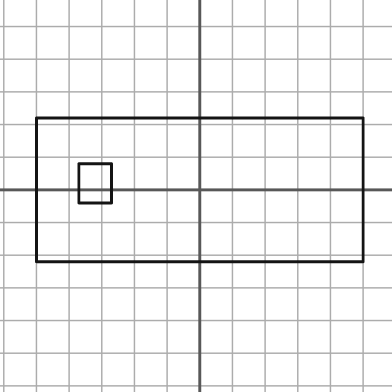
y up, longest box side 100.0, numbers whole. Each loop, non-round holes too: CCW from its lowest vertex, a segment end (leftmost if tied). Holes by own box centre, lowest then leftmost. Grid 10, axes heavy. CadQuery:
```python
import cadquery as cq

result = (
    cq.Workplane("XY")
    .moveTo(-50.0, -22.0)
    .lineTo(50.0, -22.0)
    .lineTo(50.0, 22.0)
    .lineTo(-50.0, 22.0)
    .close()
    .moveTo(-37.0, -4.0)
    .lineTo(-27.0, -4.0)
    .lineTo(-27.0, 8.0)
    .lineTo(-37.0, 8.0)
    .close()
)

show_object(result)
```